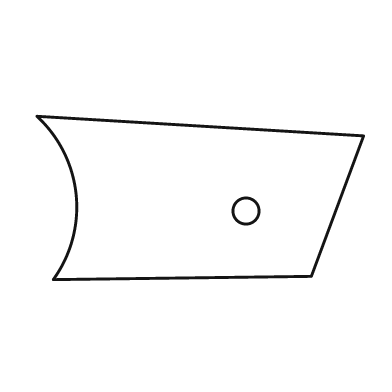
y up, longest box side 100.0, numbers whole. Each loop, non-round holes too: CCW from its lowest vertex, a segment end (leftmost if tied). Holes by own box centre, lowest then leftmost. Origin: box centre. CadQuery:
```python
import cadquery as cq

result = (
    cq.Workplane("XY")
    .moveTo(-45.0, -25.0)
    .lineTo(34.0, -24.0)
    .lineTo(50.0, 19.0)
    .lineTo(-50.0, 25.0)
    .threePointArc((-38.0, 1.0), (-45.0, -25.0))
    .close()
    .moveTo(14.0, -4.0)
    .circle(4.0)
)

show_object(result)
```